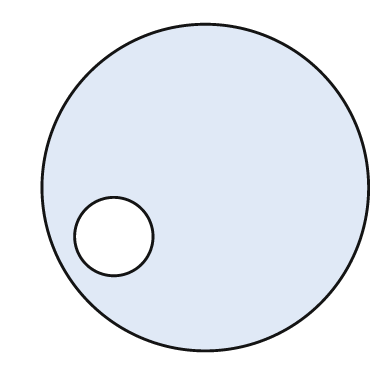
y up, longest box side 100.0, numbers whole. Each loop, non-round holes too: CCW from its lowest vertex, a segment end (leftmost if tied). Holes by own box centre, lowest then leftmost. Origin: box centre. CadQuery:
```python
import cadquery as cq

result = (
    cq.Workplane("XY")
    .moveTo(0.0, 0.0)
    .circle(50.0)
    .moveTo(-28.0, -15.0)
    .circle(12.0)
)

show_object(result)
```